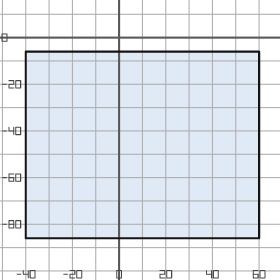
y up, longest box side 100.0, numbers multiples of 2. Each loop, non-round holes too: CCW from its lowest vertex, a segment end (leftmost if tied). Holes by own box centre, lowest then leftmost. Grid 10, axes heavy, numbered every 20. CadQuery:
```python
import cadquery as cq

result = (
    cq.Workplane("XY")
    .moveTo(-40.0, -86.0)
    .lineTo(60.0, -86.0)
    .lineTo(60.0, -6.0)
    .lineTo(-40.0, -6.0)
    .close()
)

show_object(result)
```